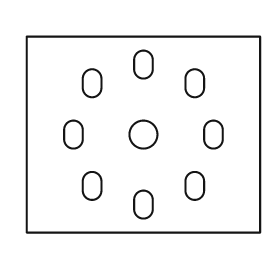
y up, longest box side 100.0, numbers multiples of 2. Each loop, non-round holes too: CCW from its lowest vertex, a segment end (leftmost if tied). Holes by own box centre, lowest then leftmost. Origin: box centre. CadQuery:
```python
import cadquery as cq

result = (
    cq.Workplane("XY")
    .moveTo(-50.0, -42.0)
    .lineTo(50.0, -42.0)
    .lineTo(50.0, 42.0)
    .lineTo(-50.0, 42.0)
    .close()
    .moveTo(-4.0, -32.0)
    .threePointArc((0.0, -36.0), (4.0, -32.0))
    .lineTo(4.0, -28.0)
    .threePointArc((0.0, -24.0), (-4.0, -28.0))
    .close()
    .moveTo(-26.0, -24.0)
    .threePointArc((-22.0, -28.0), (-18.0, -24.0))
    .lineTo(-18.0, -20.0)
    .threePointArc((-22.0, -16.0), (-26.0, -20.0))
    .close()
    .moveTo(18.0, -24.0)
    .threePointArc((22.0, -28.0), (26.0, -24.0))
    .lineTo(26.0, -20.0)
    .threePointArc((22.0, -16.0), (18.0, -20.0))
    .close()
    .moveTo(-34.0, -2.0)
    .threePointArc((-30.0, -6.0), (-26.0, -2.0))
    .lineTo(-26.0, 2.0)
    .threePointArc((-30.0, 6.0), (-34.0, 2.0))
    .close()
    .moveTo(0.0, 0.0)
    .circle(6.0)
    .moveTo(26.0, -2.0)
    .threePointArc((30.0, -6.0), (34.0, -2.0))
    .lineTo(34.0, 2.0)
    .threePointArc((30.0, 6.0), (26.0, 2.0))
    .close()
    .moveTo(-26.0, 20.0)
    .threePointArc((-22.0, 16.0), (-18.0, 20.0))
    .lineTo(-18.0, 24.0)
    .threePointArc((-22.0, 28.0), (-26.0, 24.0))
    .close()
    .moveTo(18.0, 20.0)
    .threePointArc((22.0, 16.0), (26.0, 20.0))
    .lineTo(26.0, 24.0)
    .threePointArc((22.0, 28.0), (18.0, 24.0))
    .close()
    .moveTo(-4.0, 28.0)
    .threePointArc((0.0, 24.0), (4.0, 28.0))
    .lineTo(4.0, 32.0)
    .threePointArc((0.0, 36.0), (-4.0, 32.0))
    .close()
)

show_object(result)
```